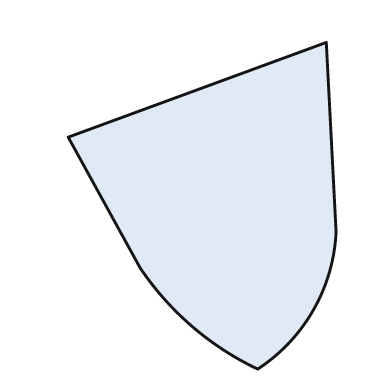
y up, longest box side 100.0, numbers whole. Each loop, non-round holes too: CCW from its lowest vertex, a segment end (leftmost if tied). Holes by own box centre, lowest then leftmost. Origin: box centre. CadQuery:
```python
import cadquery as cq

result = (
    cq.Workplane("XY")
    .moveTo(17.0, -50.0)
    .threePointArc((34.0, -32.0), (41.0, -8.0))
    .lineTo(38.0, 50.0)
    .lineTo(-41.0, 21.0)
    .lineTo(-19.0, -19.0)
    .threePointArc((-3.0, -37.0), (17.0, -50.0))
    .close()
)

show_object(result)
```